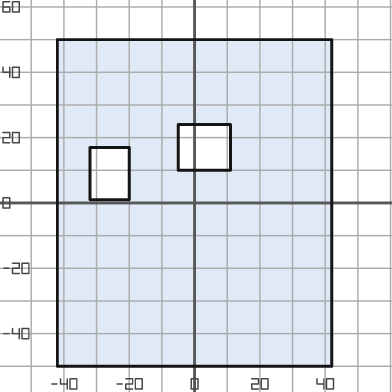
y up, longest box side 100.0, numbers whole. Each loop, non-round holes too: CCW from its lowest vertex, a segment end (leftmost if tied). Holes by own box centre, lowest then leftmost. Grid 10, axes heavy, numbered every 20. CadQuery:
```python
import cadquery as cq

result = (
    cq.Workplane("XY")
    .moveTo(-42.0, -50.0)
    .lineTo(42.0, -50.0)
    .lineTo(42.0, 50.0)
    .lineTo(-42.0, 50.0)
    .close()
    .moveTo(-32.0, 1.0)
    .lineTo(-20.0, 1.0)
    .lineTo(-20.0, 17.0)
    .lineTo(-32.0, 17.0)
    .close()
    .moveTo(-5.0, 10.0)
    .lineTo(11.0, 10.0)
    .lineTo(11.0, 24.0)
    .lineTo(-5.0, 24.0)
    .close()
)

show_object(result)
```